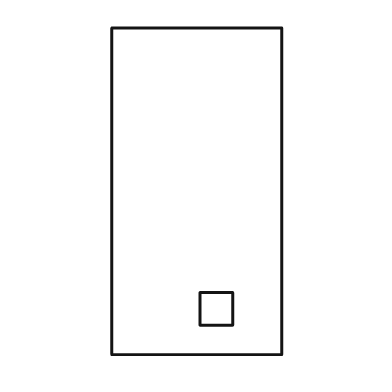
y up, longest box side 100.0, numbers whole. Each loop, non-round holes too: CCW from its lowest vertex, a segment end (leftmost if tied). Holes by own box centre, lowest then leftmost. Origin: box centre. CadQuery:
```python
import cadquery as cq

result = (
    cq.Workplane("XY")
    .moveTo(-26.0, -50.0)
    .lineTo(26.0, -50.0)
    .lineTo(26.0, 50.0)
    .lineTo(-26.0, 50.0)
    .close()
    .moveTo(1.0, -41.0)
    .lineTo(11.0, -41.0)
    .lineTo(11.0, -31.0)
    .lineTo(1.0, -31.0)
    .close()
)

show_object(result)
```